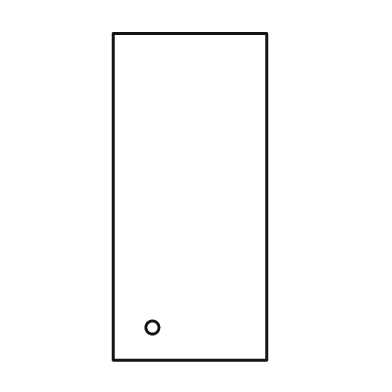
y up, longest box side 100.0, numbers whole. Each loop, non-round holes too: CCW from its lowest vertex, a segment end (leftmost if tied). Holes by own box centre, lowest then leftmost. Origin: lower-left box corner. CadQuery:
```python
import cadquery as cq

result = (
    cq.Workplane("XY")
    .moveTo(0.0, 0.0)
    .lineTo(47.0, 0.0)
    .lineTo(47.0, 100.0)
    .lineTo(0.0, 100.0)
    .close()
    .moveTo(12.0, 10.0)
    .circle(2.0)
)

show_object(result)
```